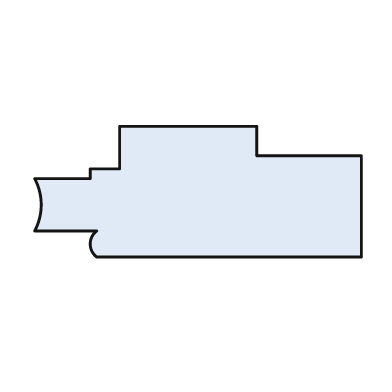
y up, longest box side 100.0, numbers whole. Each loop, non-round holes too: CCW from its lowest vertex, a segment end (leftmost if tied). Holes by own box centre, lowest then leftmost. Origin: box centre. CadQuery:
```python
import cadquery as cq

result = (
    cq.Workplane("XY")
    .moveTo(-31.0, -20.0)
    .lineTo(50.0, -20.0)
    .lineTo(50.0, 11.0)
    .lineTo(18.0, 11.0)
    .lineTo(18.0, 20.0)
    .lineTo(-24.0, 20.0)
    .lineTo(-24.0, 7.0)
    .lineTo(-33.0, 7.0)
    .lineTo(-33.0, 4.0)
    .lineTo(-50.0, 4.0)
    .threePointArc((-48.0, -4.0), (-50.0, -12.0))
    .lineTo(-31.0, -12.0)
    .threePointArc((-33.0, -16.0), (-31.0, -20.0))
    .close()
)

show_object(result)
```